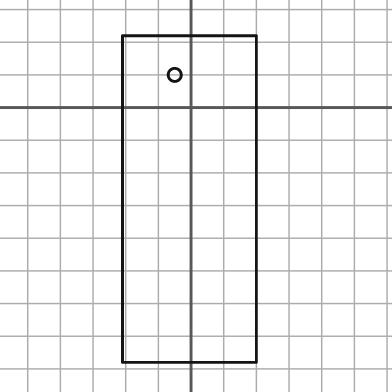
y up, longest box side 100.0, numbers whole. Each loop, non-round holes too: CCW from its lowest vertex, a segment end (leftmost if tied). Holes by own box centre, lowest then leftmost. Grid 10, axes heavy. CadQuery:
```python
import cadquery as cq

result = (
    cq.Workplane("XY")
    .moveTo(-21.0, -78.0)
    .lineTo(20.0, -78.0)
    .lineTo(20.0, 22.0)
    .lineTo(-21.0, 22.0)
    .close()
    .moveTo(-5.0, 10.0)
    .circle(2.0)
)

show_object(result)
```